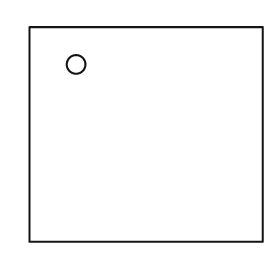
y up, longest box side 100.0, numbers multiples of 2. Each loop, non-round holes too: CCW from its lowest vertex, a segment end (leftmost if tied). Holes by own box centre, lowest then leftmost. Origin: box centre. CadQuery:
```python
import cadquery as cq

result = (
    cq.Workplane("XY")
    .moveTo(-50.0, -46.0)
    .lineTo(50.0, -46.0)
    .lineTo(50.0, 46.0)
    .lineTo(-50.0, 46.0)
    .close()
    .moveTo(-30.0, 30.0)
    .circle(4.0)
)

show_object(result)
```